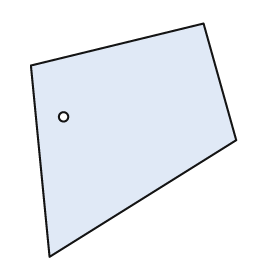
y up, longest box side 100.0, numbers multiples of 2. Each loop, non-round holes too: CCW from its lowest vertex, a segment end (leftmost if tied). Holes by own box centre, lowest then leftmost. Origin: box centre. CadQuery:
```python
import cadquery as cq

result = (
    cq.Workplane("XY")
    .moveTo(-36.0, -50.0)
    .lineTo(44.0, 0.0)
    .lineTo(30.0, 50.0)
    .lineTo(-44.0, 32.0)
    .close()
    .moveTo(-30.0, 10.0)
    .circle(2.0)
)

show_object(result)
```